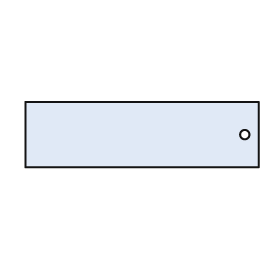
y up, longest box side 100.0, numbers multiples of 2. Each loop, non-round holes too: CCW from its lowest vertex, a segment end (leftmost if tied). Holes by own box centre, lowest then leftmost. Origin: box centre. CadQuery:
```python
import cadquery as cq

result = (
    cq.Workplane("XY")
    .moveTo(-50.0, -14.0)
    .lineTo(50.0, -14.0)
    .lineTo(50.0, 14.0)
    .lineTo(-50.0, 14.0)
    .close()
    .moveTo(44.0, 0.0)
    .circle(2.0)
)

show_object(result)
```